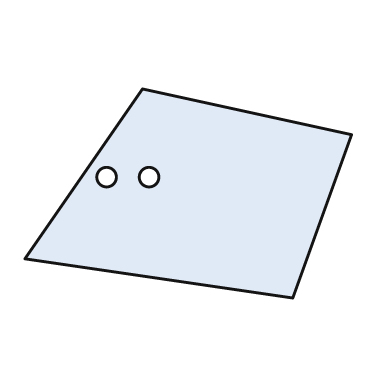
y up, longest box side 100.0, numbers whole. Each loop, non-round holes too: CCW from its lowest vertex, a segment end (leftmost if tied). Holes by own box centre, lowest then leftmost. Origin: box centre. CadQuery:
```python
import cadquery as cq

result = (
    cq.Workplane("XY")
    .moveTo(32.0, -32.0)
    .lineTo(50.0, 18.0)
    .lineTo(-14.0, 32.0)
    .lineTo(-50.0, -20.0)
    .close()
    .moveTo(-25.0, 5.0)
    .circle(3.0)
    .moveTo(-12.0, 5.0)
    .circle(3.0)
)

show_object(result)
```